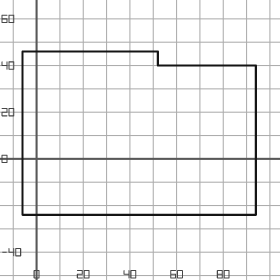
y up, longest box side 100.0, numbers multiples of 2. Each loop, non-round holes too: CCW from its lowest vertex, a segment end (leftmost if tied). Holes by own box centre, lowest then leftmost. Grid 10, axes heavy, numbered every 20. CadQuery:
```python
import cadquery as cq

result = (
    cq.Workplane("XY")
    .moveTo(-6.0, -24.0)
    .lineTo(94.0, -24.0)
    .lineTo(94.0, 40.0)
    .lineTo(52.0, 40.0)
    .lineTo(52.0, 46.0)
    .lineTo(-6.0, 46.0)
    .close()
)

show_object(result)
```